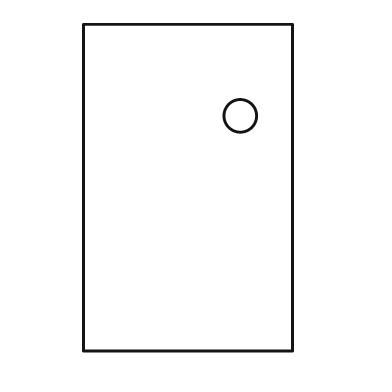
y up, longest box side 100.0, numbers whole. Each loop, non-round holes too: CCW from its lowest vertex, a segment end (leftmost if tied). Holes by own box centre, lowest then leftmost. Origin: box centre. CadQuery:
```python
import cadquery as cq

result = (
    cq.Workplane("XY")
    .moveTo(-32.0, -50.0)
    .lineTo(32.0, -50.0)
    .lineTo(32.0, 50.0)
    .lineTo(-32.0, 50.0)
    .close()
    .moveTo(16.0, 22.0)
    .circle(5.0)
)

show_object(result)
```